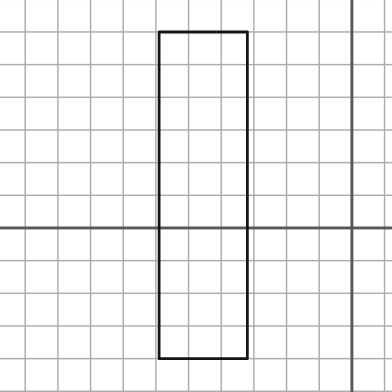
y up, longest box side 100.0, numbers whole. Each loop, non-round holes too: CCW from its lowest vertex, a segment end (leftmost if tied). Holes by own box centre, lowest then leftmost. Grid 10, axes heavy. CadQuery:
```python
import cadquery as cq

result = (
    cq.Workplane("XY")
    .moveTo(-59.0, -40.0)
    .lineTo(-32.0, -40.0)
    .lineTo(-32.0, 60.0)
    .lineTo(-59.0, 60.0)
    .close()
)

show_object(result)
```